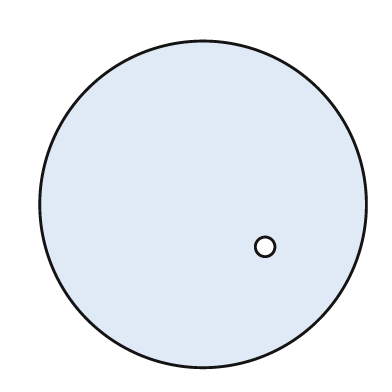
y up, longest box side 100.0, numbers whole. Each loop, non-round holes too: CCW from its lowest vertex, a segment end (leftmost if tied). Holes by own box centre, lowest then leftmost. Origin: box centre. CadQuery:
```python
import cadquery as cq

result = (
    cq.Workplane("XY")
    .moveTo(0.0, 0.0)
    .circle(50.0)
    .moveTo(19.0, -13.0)
    .circle(3.0)
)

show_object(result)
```